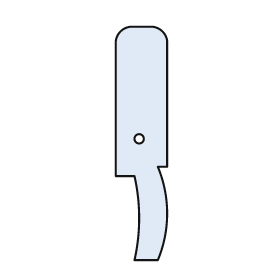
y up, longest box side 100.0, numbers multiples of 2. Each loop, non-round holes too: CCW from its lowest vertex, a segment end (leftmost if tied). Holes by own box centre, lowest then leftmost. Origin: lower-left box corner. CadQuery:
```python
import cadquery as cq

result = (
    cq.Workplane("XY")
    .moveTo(8.0, 0.0)
    .lineTo(18.0, 0.0)
    .threePointArc((22.0, 20.0), (18.0, 40.0))
    .lineTo(22.0, 40.0)
    .lineTo(22.0, 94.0)
    .threePointArc((20.0, 98.0), (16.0, 100.0))
    .lineTo(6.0, 100.0)
    .threePointArc((2.0, 98.0), (0.0, 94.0))
    .lineTo(0.0, 36.0)
    .lineTo(8.0, 36.0)
    .threePointArc((10.0, 18.0), (8.0, 0.0))
    .close()
    .moveTo(10.0, 52.0)
    .circle(2.0)
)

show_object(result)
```